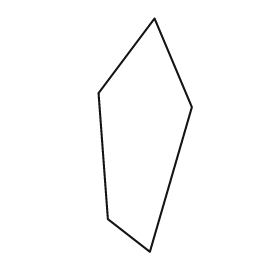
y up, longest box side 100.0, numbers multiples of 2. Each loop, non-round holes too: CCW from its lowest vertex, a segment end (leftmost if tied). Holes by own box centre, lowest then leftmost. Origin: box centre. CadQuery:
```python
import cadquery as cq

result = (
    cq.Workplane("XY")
    .moveTo(2.0, -50.0)
    .lineTo(20.0, 12.0)
    .lineTo(4.0, 50.0)
    .lineTo(-20.0, 18.0)
    .lineTo(-16.0, -36.0)
    .close()
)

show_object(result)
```